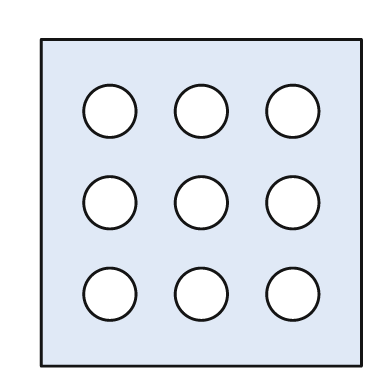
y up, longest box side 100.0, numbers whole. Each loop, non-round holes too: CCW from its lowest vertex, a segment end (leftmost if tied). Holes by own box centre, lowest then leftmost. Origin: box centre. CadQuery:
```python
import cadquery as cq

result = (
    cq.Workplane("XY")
    .moveTo(-49.0, -50.0)
    .lineTo(49.0, -50.0)
    .lineTo(49.0, 50.0)
    .lineTo(-49.0, 50.0)
    .close()
    .moveTo(-28.0, -28.0)
    .circle(8.0)
    .moveTo(0.0, -28.0)
    .circle(8.0)
    .moveTo(28.0, -28.0)
    .circle(8.0)
    .moveTo(-28.0, 0.0)
    .circle(8.0)
    .moveTo(0.0, 0.0)
    .circle(8.0)
    .moveTo(28.0, 0.0)
    .circle(8.0)
    .moveTo(-28.0, 28.0)
    .circle(8.0)
    .moveTo(0.0, 28.0)
    .circle(8.0)
    .moveTo(28.0, 28.0)
    .circle(8.0)
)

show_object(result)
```